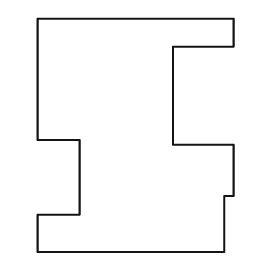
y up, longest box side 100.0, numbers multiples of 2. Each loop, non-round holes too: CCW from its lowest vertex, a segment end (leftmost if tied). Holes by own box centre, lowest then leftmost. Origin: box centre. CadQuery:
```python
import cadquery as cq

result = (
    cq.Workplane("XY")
    .moveTo(-42.0, -50.0)
    .lineTo(38.0, -50.0)
    .lineTo(38.0, -26.0)
    .lineTo(42.0, -26.0)
    .lineTo(42.0, -4.0)
    .lineTo(16.0, -4.0)
    .lineTo(16.0, 38.0)
    .lineTo(42.0, 38.0)
    .lineTo(42.0, 50.0)
    .lineTo(-42.0, 50.0)
    .lineTo(-42.0, -2.0)
    .lineTo(-24.0, -2.0)
    .lineTo(-24.0, -34.0)
    .lineTo(-42.0, -34.0)
    .close()
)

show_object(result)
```